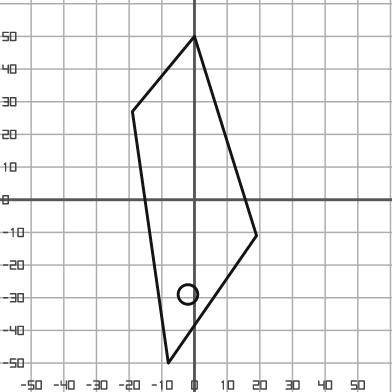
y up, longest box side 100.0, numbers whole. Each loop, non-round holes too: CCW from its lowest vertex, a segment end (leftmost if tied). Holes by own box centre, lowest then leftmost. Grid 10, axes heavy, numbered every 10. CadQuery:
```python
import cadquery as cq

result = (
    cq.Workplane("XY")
    .moveTo(-8.0, -50.0)
    .lineTo(19.0, -11.0)
    .lineTo(0.0, 50.0)
    .lineTo(-19.0, 27.0)
    .close()
    .moveTo(-2.0, -29.0)
    .circle(3.0)
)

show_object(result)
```